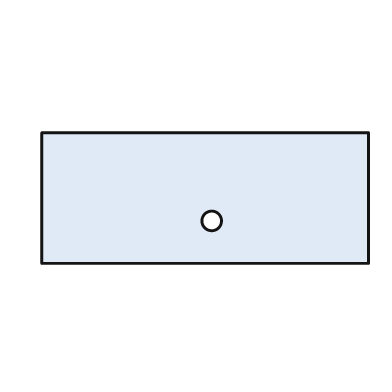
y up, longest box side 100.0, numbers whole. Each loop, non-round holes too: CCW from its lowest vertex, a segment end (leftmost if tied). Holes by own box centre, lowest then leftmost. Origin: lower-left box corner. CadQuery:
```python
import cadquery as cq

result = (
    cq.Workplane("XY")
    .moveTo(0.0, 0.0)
    .lineTo(100.0, 0.0)
    .lineTo(100.0, 40.0)
    .lineTo(0.0, 40.0)
    .close()
    .moveTo(52.0, 13.0)
    .circle(3.0)
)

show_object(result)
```